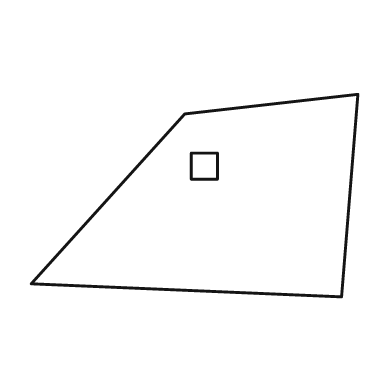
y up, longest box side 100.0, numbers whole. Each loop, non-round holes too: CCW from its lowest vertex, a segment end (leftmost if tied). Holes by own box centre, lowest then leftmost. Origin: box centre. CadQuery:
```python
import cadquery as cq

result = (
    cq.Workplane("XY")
    .moveTo(45.0, -31.0)
    .lineTo(50.0, 31.0)
    .lineTo(-3.0, 25.0)
    .lineTo(-50.0, -27.0)
    .close()
    .moveTo(-1.0, 5.0)
    .lineTo(7.0, 5.0)
    .lineTo(7.0, 13.0)
    .lineTo(-1.0, 13.0)
    .close()
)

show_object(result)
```